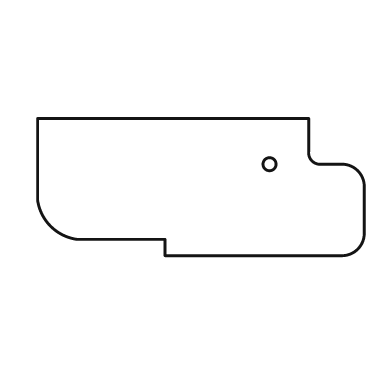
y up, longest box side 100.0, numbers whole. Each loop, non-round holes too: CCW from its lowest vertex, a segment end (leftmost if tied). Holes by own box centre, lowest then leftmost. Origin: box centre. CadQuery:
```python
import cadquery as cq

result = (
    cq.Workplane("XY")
    .moveTo(-11.0, -21.0)
    .lineTo(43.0, -21.0)
    .threePointArc((48.0, -19.0), (50.0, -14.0))
    .lineTo(50.0, 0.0)
    .threePointArc((48.0, 5.0), (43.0, 7.0))
    .lineTo(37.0, 7.0)
    .threePointArc((34.0, 8.0), (33.0, 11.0))
    .lineTo(33.0, 21.0)
    .lineTo(-50.0, 21.0)
    .lineTo(-50.0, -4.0)
    .threePointArc((-46.0, -12.0), (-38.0, -16.0))
    .lineTo(-11.0, -16.0)
    .close()
    .moveTo(21.0, 7.0)
    .circle(2.0)
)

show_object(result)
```